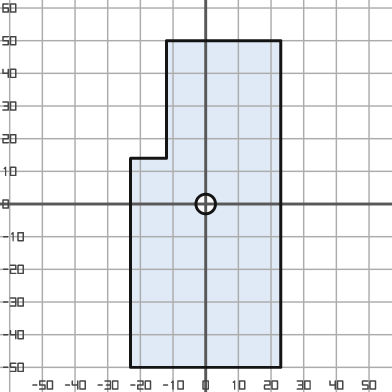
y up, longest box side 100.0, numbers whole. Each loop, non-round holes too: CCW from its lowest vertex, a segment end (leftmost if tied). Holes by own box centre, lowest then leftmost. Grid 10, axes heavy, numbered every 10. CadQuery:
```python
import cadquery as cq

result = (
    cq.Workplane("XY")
    .moveTo(-23.0, -50.0)
    .lineTo(23.0, -50.0)
    .lineTo(23.0, 50.0)
    .lineTo(-12.0, 50.0)
    .lineTo(-12.0, 14.0)
    .lineTo(-23.0, 14.0)
    .close()
    .moveTo(0.0, 0.0)
    .circle(3.0)
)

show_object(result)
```